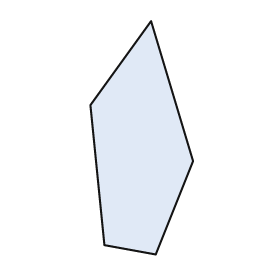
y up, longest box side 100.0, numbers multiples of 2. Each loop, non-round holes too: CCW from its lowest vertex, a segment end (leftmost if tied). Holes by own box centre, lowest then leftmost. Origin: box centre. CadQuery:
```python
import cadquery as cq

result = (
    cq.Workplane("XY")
    .moveTo(6.0, -50.0)
    .lineTo(22.0, -10.0)
    .lineTo(4.0, 50.0)
    .lineTo(-22.0, 14.0)
    .lineTo(-16.0, -46.0)
    .close()
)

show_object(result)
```